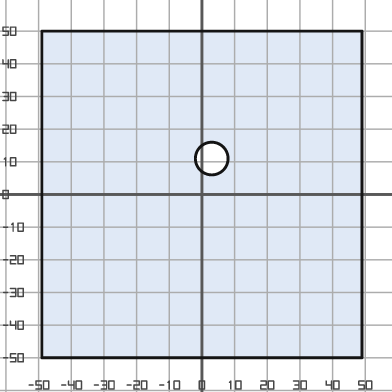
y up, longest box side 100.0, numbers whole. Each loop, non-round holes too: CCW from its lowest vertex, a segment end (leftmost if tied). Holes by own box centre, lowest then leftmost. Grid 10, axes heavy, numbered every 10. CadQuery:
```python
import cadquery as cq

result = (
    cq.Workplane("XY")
    .moveTo(-49.0, -50.0)
    .lineTo(49.0, -50.0)
    .lineTo(49.0, 50.0)
    .lineTo(-49.0, 50.0)
    .close()
    .moveTo(3.0, 11.0)
    .circle(5.0)
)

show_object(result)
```